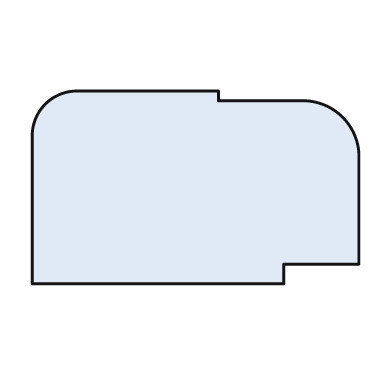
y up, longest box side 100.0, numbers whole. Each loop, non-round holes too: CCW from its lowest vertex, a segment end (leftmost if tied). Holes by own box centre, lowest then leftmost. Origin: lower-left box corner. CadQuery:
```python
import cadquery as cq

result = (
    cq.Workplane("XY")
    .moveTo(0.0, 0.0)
    .lineTo(77.0, 0.0)
    .lineTo(77.0, 6.0)
    .lineTo(100.0, 6.0)
    .lineTo(100.0, 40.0)
    .threePointArc((95.0, 51.0), (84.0, 56.0))
    .lineTo(57.0, 56.0)
    .lineTo(57.0, 59.0)
    .lineTo(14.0, 59.0)
    .threePointArc((4.0, 55.0), (0.0, 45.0))
    .close()
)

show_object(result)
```